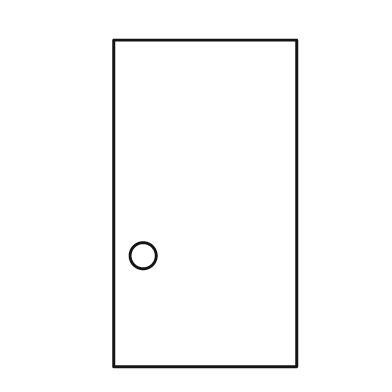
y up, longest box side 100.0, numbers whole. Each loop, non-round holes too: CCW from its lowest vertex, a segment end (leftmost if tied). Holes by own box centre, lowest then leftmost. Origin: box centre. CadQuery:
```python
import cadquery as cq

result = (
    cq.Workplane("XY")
    .moveTo(-28.0, -50.0)
    .lineTo(28.0, -50.0)
    .lineTo(28.0, 50.0)
    .lineTo(-28.0, 50.0)
    .close()
    .moveTo(-19.0, -16.0)
    .circle(4.0)
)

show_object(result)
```